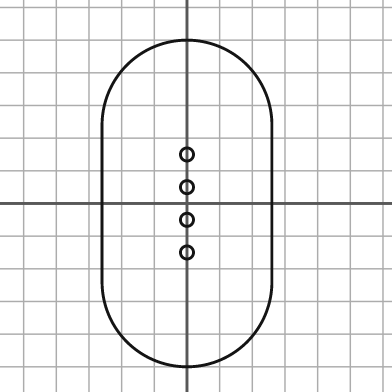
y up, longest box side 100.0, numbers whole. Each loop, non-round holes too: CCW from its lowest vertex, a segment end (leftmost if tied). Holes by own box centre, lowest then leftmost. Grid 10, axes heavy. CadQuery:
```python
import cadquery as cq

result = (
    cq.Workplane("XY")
    .moveTo(-26.0, -24.0)
    .threePointArc((0.0, -50.0), (26.0, -24.0))
    .lineTo(26.0, 24.0)
    .threePointArc((0.0, 50.0), (-26.0, 24.0))
    .close()
    .moveTo(0.0, -15.0)
    .circle(2.0)
    .moveTo(0.0, -5.0)
    .circle(2.0)
    .moveTo(0.0, 5.0)
    .circle(2.0)
    .moveTo(0.0, 15.0)
    .circle(2.0)
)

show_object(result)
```